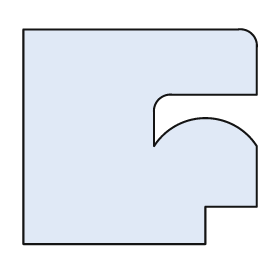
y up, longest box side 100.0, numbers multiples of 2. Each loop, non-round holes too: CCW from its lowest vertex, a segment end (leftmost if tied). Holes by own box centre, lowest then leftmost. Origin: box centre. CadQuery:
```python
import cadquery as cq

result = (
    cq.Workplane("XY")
    .moveTo(-50.0, -46.0)
    .lineTo(28.0, -46.0)
    .lineTo(28.0, -30.0)
    .lineTo(50.0, -30.0)
    .lineTo(50.0, -4.0)
    .threePointArc((28.0, 8.0), (6.0, -4.0))
    .lineTo(6.0, 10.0)
    .threePointArc((8.0, 16.0), (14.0, 18.0))
    .lineTo(50.0, 18.0)
    .lineTo(50.0, 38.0)
    .threePointArc((48.0, 44.0), (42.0, 46.0))
    .lineTo(-50.0, 46.0)
    .close()
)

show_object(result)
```